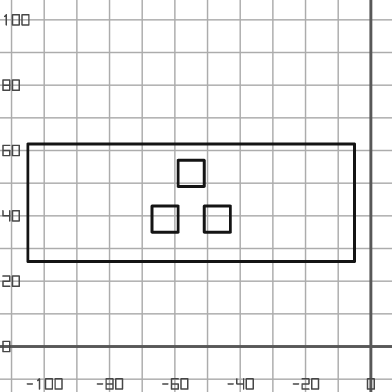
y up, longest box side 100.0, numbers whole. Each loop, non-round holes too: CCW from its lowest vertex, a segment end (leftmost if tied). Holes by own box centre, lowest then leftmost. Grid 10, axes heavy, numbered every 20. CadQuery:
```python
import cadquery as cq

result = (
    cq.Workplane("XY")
    .moveTo(-105.0, 26.0)
    .lineTo(-5.0, 26.0)
    .lineTo(-5.0, 62.0)
    .lineTo(-105.0, 62.0)
    .close()
    .moveTo(-67.0, 35.0)
    .lineTo(-59.0, 35.0)
    .lineTo(-59.0, 43.0)
    .lineTo(-67.0, 43.0)
    .close()
    .moveTo(-51.0, 35.0)
    .lineTo(-43.0, 35.0)
    .lineTo(-43.0, 43.0)
    .lineTo(-51.0, 43.0)
    .close()
    .moveTo(-59.0, 49.0)
    .lineTo(-51.0, 49.0)
    .lineTo(-51.0, 57.0)
    .lineTo(-59.0, 57.0)
    .close()
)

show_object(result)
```